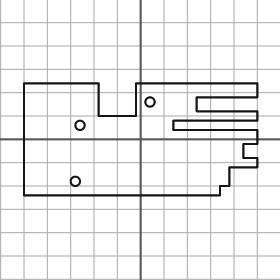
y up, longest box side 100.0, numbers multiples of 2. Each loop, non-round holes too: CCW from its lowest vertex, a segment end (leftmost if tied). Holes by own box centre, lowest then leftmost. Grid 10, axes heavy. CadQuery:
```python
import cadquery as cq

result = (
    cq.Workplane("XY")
    .moveTo(-50.0, -24.0)
    .lineTo(34.0, -24.0)
    .lineTo(34.0, -20.0)
    .lineTo(38.0, -20.0)
    .lineTo(38.0, -12.0)
    .lineTo(50.0, -12.0)
    .lineTo(50.0, -8.0)
    .lineTo(44.0, -8.0)
    .lineTo(44.0, -2.0)
    .lineTo(50.0, -2.0)
    .lineTo(50.0, 4.0)
    .lineTo(14.0, 4.0)
    .lineTo(14.0, 8.0)
    .lineTo(50.0, 8.0)
    .lineTo(50.0, 12.0)
    .lineTo(24.0, 12.0)
    .lineTo(24.0, 18.0)
    .lineTo(50.0, 18.0)
    .lineTo(50.0, 24.0)
    .lineTo(-2.0, 24.0)
    .lineTo(-2.0, 10.0)
    .lineTo(-18.0, 10.0)
    .lineTo(-18.0, 24.0)
    .lineTo(-50.0, 24.0)
    .close()
    .moveTo(-28.0, -18.0)
    .circle(2.0)
    .moveTo(-26.0, 6.0)
    .circle(2.0)
    .moveTo(4.0, 16.0)
    .circle(2.0)
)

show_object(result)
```